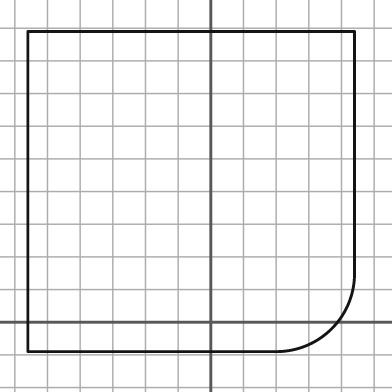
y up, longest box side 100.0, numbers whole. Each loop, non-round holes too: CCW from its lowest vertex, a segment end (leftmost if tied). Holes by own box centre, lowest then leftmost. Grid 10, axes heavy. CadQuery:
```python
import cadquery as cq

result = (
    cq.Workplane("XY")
    .moveTo(-56.0, -9.0)
    .lineTo(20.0, -9.0)
    .threePointArc((37.0, -2.0), (44.0, 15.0))
    .lineTo(44.0, 89.0)
    .lineTo(-56.0, 89.0)
    .close()
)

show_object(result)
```